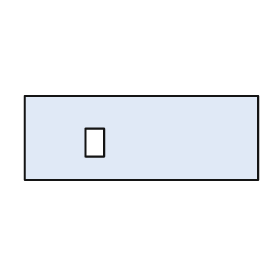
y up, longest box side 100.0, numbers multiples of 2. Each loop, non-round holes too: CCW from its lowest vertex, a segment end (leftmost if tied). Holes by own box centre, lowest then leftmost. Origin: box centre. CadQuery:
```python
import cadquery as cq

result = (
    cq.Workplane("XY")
    .moveTo(-50.0, -18.0)
    .lineTo(50.0, -18.0)
    .lineTo(50.0, 18.0)
    .lineTo(-50.0, 18.0)
    .close()
    .moveTo(-24.0, -8.0)
    .lineTo(-16.0, -8.0)
    .lineTo(-16.0, 4.0)
    .lineTo(-24.0, 4.0)
    .close()
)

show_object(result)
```